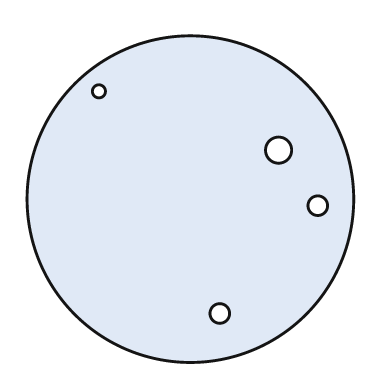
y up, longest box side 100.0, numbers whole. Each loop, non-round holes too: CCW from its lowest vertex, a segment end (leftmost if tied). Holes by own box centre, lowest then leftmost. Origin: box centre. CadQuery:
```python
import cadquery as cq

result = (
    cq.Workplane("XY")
    .moveTo(0.0, 0.0)
    .circle(50.0)
    .moveTo(9.0, -35.0)
    .circle(3.0)
    .moveTo(39.0, -2.0)
    .circle(3.0)
    .moveTo(27.0, 15.0)
    .circle(4.0)
    .moveTo(-28.0, 33.0)
    .circle(2.0)
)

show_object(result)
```